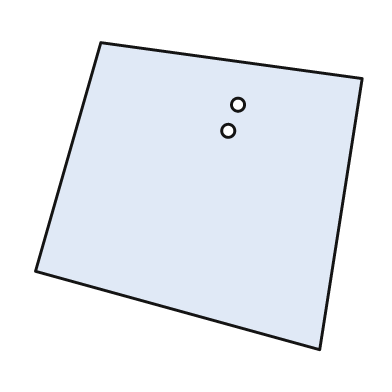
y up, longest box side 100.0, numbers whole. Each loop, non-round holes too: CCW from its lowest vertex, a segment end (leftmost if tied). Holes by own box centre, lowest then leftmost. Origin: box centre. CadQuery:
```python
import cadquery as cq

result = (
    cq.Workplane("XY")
    .moveTo(37.0, -47.0)
    .lineTo(50.0, 36.0)
    .lineTo(-30.0, 47.0)
    .lineTo(-50.0, -23.0)
    .close()
    .moveTo(9.0, 20.0)
    .circle(2.0)
    .moveTo(12.0, 28.0)
    .circle(2.0)
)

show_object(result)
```